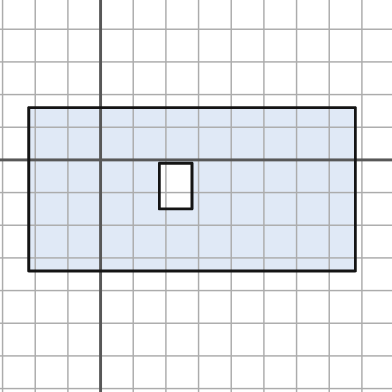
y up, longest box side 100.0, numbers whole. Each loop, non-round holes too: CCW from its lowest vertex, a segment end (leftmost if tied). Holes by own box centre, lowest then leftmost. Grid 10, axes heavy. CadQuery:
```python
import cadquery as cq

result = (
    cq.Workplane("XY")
    .moveTo(-22.0, -34.0)
    .lineTo(78.0, -34.0)
    .lineTo(78.0, 16.0)
    .lineTo(-22.0, 16.0)
    .close()
    .moveTo(18.0, -15.0)
    .lineTo(28.0, -15.0)
    .lineTo(28.0, -1.0)
    .lineTo(18.0, -1.0)
    .close()
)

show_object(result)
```